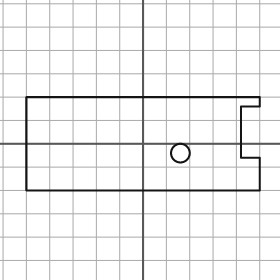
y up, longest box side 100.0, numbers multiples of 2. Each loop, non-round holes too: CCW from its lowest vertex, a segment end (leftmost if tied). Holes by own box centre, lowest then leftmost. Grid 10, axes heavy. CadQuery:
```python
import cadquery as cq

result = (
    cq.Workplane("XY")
    .moveTo(-50.0, -20.0)
    .lineTo(50.0, -20.0)
    .lineTo(50.0, -6.0)
    .lineTo(42.0, -6.0)
    .lineTo(42.0, 16.0)
    .lineTo(50.0, 16.0)
    .lineTo(50.0, 20.0)
    .lineTo(-50.0, 20.0)
    .close()
    .moveTo(16.0, -4.0)
    .circle(4.0)
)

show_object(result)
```